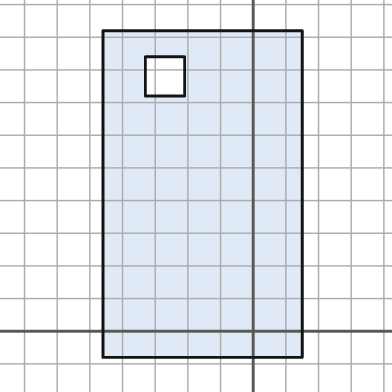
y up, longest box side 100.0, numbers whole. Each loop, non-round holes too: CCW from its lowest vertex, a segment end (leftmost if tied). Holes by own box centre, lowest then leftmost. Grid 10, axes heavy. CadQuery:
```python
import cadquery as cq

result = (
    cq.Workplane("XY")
    .moveTo(-46.0, -8.0)
    .lineTo(15.0, -8.0)
    .lineTo(15.0, 92.0)
    .lineTo(-46.0, 92.0)
    .close()
    .moveTo(-33.0, 72.0)
    .lineTo(-21.0, 72.0)
    .lineTo(-21.0, 84.0)
    .lineTo(-33.0, 84.0)
    .close()
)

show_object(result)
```